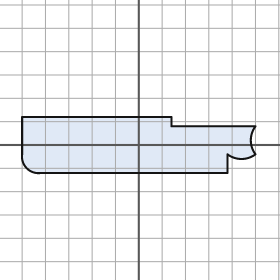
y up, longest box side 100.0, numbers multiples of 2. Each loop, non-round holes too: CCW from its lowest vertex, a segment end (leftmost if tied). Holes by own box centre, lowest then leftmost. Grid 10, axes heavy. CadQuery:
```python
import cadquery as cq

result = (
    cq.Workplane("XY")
    .moveTo(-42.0, -12.0)
    .lineTo(38.0, -12.0)
    .lineTo(38.0, -4.0)
    .threePointArc((44.0, -6.0), (50.0, -4.0))
    .threePointArc((48.0, 2.0), (50.0, 8.0))
    .lineTo(14.0, 8.0)
    .lineTo(14.0, 12.0)
    .lineTo(-50.0, 12.0)
    .lineTo(-50.0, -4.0)
    .threePointArc((-48.0, -10.0), (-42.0, -12.0))
    .close()
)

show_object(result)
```